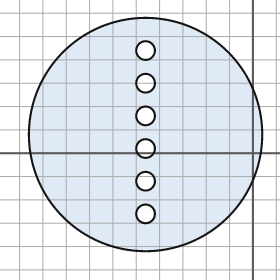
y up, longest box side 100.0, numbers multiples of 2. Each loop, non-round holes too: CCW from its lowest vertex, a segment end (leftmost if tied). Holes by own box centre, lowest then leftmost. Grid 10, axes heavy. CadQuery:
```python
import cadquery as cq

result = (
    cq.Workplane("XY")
    .moveTo(-46.0, 8.0)
    .circle(50.0)
    .moveTo(-46.0, -26.0)
    .circle(4.0)
    .moveTo(-46.0, -12.0)
    .circle(4.0)
    .moveTo(-46.0, 2.0)
    .circle(4.0)
    .moveTo(-46.0, 16.0)
    .circle(4.0)
    .moveTo(-46.0, 30.0)
    .circle(4.0)
    .moveTo(-46.0, 44.0)
    .circle(4.0)
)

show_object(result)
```